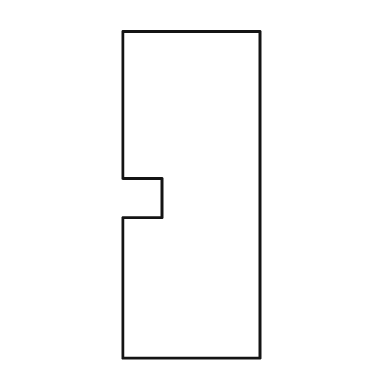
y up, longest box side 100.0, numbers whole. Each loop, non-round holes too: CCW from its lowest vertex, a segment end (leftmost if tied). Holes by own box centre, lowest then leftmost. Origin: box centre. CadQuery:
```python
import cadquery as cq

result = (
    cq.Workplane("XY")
    .moveTo(-21.0, -50.0)
    .lineTo(21.0, -50.0)
    .lineTo(21.0, 50.0)
    .lineTo(-21.0, 50.0)
    .lineTo(-21.0, 5.0)
    .lineTo(-9.0, 5.0)
    .lineTo(-9.0, -7.0)
    .lineTo(-21.0, -7.0)
    .close()
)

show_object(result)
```